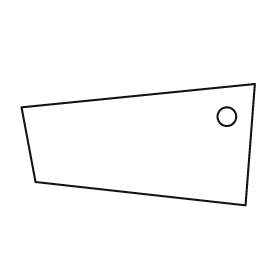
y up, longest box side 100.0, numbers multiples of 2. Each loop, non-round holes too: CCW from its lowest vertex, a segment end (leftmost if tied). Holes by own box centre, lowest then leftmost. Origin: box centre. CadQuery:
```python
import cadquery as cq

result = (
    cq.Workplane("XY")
    .moveTo(46.0, -26.0)
    .lineTo(50.0, 26.0)
    .lineTo(-50.0, 16.0)
    .lineTo(-44.0, -16.0)
    .close()
    .moveTo(38.0, 12.0)
    .circle(4.0)
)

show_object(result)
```